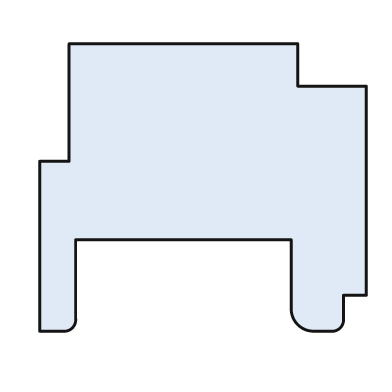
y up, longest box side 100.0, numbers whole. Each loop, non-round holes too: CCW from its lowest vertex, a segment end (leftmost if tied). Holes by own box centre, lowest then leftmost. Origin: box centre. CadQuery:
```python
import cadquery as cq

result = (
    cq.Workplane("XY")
    .moveTo(-50.0, -44.0)
    .lineTo(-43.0, -44.0)
    .threePointArc((-40.0, -43.0), (-39.0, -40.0))
    .lineTo(-39.0, -16.0)
    .lineTo(27.0, -16.0)
    .lineTo(27.0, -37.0)
    .threePointArc((29.0, -42.0), (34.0, -44.0))
    .lineTo(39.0, -44.0)
    .threePointArc((42.0, -43.0), (43.0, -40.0))
    .lineTo(43.0, -33.0)
    .lineTo(50.0, -33.0)
    .lineTo(50.0, 31.0)
    .lineTo(29.0, 31.0)
    .lineTo(29.0, 44.0)
    .lineTo(-41.0, 44.0)
    .lineTo(-41.0, 8.0)
    .lineTo(-50.0, 8.0)
    .close()
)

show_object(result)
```